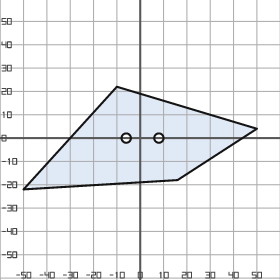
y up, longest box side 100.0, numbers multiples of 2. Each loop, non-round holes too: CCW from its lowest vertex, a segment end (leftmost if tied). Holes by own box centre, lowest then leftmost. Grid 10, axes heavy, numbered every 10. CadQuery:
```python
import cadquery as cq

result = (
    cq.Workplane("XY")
    .moveTo(-50.0, -22.0)
    .lineTo(16.0, -18.0)
    .lineTo(50.0, 4.0)
    .lineTo(-10.0, 22.0)
    .close()
    .moveTo(-6.0, 0.0)
    .circle(2.0)
    .moveTo(8.0, 0.0)
    .circle(2.0)
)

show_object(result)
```